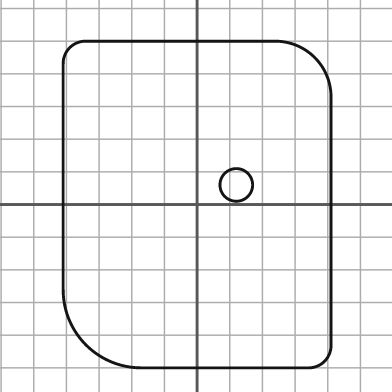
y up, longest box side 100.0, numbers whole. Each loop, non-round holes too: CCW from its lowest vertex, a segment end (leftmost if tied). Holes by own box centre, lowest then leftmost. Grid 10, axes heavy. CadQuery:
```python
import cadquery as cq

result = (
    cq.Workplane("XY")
    .moveTo(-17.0, -50.0)
    .lineTo(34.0, -50.0)
    .threePointArc((39.0, -48.0), (41.0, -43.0))
    .lineTo(41.0, 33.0)
    .threePointArc((36.0, 45.0), (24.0, 50.0))
    .lineTo(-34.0, 50.0)
    .threePointArc((-39.0, 48.0), (-41.0, 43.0))
    .lineTo(-41.0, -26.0)
    .threePointArc((-34.0, -43.0), (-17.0, -50.0))
    .close()
    .moveTo(12.0, 6.0)
    .circle(5.0)
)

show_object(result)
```